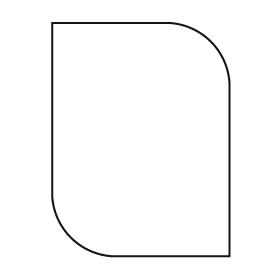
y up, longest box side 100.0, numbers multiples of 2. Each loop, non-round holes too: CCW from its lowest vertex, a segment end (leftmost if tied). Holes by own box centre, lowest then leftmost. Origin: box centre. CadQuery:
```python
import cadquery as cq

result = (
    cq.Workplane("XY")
    .moveTo(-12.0, -50.0)
    .lineTo(38.0, -50.0)
    .lineTo(38.0, 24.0)
    .threePointArc((30.0, 42.0), (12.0, 50.0))
    .lineTo(-38.0, 50.0)
    .lineTo(-38.0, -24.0)
    .threePointArc((-30.0, -42.0), (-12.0, -50.0))
    .close()
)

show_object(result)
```